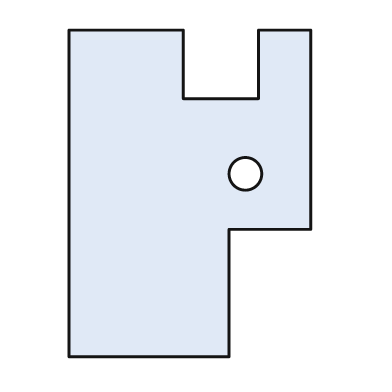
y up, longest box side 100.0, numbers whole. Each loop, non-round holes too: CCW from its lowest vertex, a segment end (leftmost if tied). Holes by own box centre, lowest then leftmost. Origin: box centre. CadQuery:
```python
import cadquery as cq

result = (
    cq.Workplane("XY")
    .moveTo(-37.0, -50.0)
    .lineTo(12.0, -50.0)
    .lineTo(12.0, -11.0)
    .lineTo(37.0, -11.0)
    .lineTo(37.0, 50.0)
    .lineTo(21.0, 50.0)
    .lineTo(21.0, 29.0)
    .lineTo(-2.0, 29.0)
    .lineTo(-2.0, 50.0)
    .lineTo(-37.0, 50.0)
    .close()
    .moveTo(17.0, 6.0)
    .circle(5.0)
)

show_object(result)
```